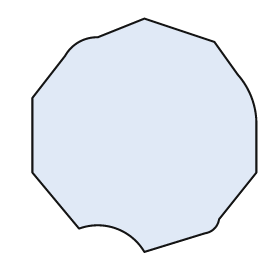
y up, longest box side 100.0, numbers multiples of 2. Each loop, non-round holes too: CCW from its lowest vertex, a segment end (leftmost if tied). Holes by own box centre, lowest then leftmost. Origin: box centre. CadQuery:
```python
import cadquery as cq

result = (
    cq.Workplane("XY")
    .moveTo(0.0, -50.0)
    .lineTo(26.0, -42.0)
    .threePointArc((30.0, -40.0), (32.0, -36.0))
    .lineTo(48.0, -16.0)
    .lineTo(48.0, 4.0)
    .threePointArc((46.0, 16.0), (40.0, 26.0))
    .lineTo(30.0, 40.0)
    .lineTo(0.0, 50.0)
    .lineTo(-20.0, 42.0)
    .threePointArc((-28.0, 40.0), (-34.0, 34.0))
    .lineTo(-48.0, 16.0)
    .lineTo(-48.0, -16.0)
    .lineTo(-28.0, -40.0)
    .threePointArc((-12.0, -40.0), (0.0, -50.0))
    .close()
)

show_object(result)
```